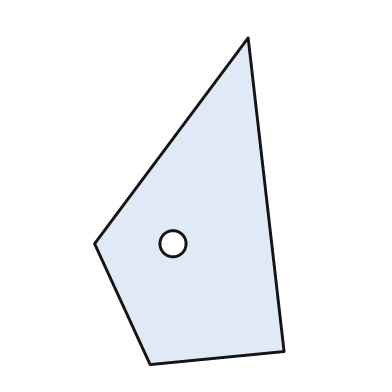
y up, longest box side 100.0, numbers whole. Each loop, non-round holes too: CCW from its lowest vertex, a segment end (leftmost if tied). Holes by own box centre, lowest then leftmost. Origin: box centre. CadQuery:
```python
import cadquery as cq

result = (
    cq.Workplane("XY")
    .moveTo(-12.0, -50.0)
    .lineTo(29.0, -46.0)
    .lineTo(18.0, 50.0)
    .lineTo(-29.0, -13.0)
    .close()
    .moveTo(-5.0, -13.0)
    .circle(4.0)
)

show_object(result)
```